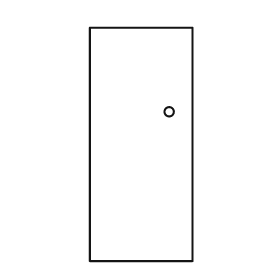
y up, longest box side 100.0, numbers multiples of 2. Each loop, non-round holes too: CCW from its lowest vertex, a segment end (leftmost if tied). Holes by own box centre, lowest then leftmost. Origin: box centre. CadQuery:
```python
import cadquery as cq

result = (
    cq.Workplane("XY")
    .moveTo(-22.0, -50.0)
    .lineTo(22.0, -50.0)
    .lineTo(22.0, 50.0)
    .lineTo(-22.0, 50.0)
    .close()
    .moveTo(12.0, 14.0)
    .circle(2.0)
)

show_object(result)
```